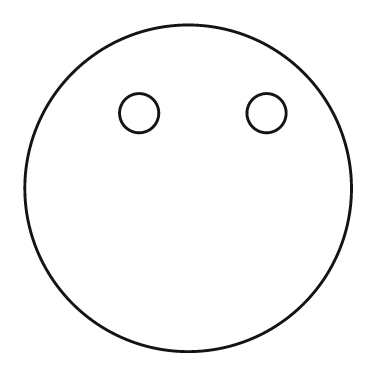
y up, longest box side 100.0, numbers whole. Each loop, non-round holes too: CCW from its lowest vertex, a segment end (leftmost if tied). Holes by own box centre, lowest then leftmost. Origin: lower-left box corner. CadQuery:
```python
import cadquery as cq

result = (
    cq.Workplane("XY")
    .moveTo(50.0, 50.0)
    .circle(50.0)
    .moveTo(35.0, 73.0)
    .circle(6.0)
    .moveTo(74.0, 73.0)
    .circle(6.0)
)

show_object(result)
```